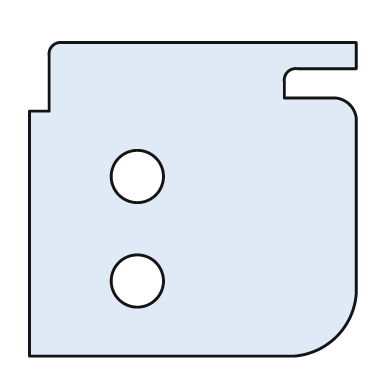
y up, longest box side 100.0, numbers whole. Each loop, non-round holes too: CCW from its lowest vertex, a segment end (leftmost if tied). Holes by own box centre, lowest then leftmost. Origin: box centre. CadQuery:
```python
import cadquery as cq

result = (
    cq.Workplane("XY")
    .moveTo(-50.0, -48.0)
    .lineTo(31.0, -48.0)
    .threePointArc((44.0, -42.0), (50.0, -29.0))
    .lineTo(50.0, 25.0)
    .threePointArc((48.0, 29.0), (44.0, 31.0))
    .lineTo(28.0, 31.0)
    .lineTo(28.0, 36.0)
    .threePointArc((29.0, 39.0), (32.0, 40.0))
    .lineTo(50.0, 40.0)
    .lineTo(50.0, 48.0)
    .lineTo(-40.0, 48.0)
    .threePointArc((-43.0, 47.0), (-44.0, 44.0))
    .lineTo(-44.0, 27.0)
    .lineTo(-50.0, 27.0)
    .close()
    .moveTo(-17.0, -25.0)
    .circle(8.0)
    .moveTo(-17.0, 7.0)
    .circle(8.0)
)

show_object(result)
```